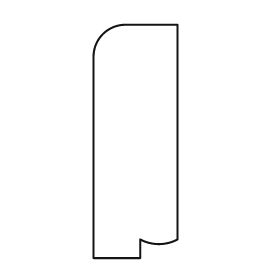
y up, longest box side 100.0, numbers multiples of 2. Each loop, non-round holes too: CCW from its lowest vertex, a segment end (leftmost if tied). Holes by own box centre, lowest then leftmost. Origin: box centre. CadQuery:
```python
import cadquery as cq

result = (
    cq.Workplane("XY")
    .moveTo(-18.0, -50.0)
    .lineTo(2.0, -50.0)
    .lineTo(2.0, -42.0)
    .threePointArc((10.0, -44.0), (18.0, -42.0))
    .lineTo(18.0, 50.0)
    .lineTo(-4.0, 50.0)
    .threePointArc((-14.0, 46.0), (-18.0, 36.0))
    .close()
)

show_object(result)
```